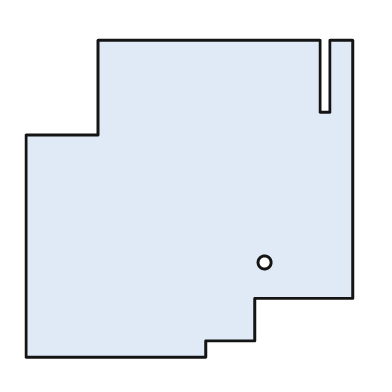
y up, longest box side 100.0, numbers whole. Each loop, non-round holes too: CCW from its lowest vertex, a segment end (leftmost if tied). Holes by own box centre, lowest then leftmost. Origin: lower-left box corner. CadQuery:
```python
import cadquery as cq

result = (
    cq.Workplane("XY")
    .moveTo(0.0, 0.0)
    .lineTo(55.0, 0.0)
    .lineTo(55.0, 5.0)
    .lineTo(70.0, 5.0)
    .lineTo(70.0, 18.0)
    .lineTo(100.0, 18.0)
    .lineTo(100.0, 97.0)
    .lineTo(93.0, 97.0)
    .lineTo(93.0, 75.0)
    .lineTo(90.0, 75.0)
    .lineTo(90.0, 97.0)
    .lineTo(22.0, 97.0)
    .lineTo(22.0, 68.0)
    .lineTo(0.0, 68.0)
    .close()
    .moveTo(73.0, 29.0)
    .circle(2.0)
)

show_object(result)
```